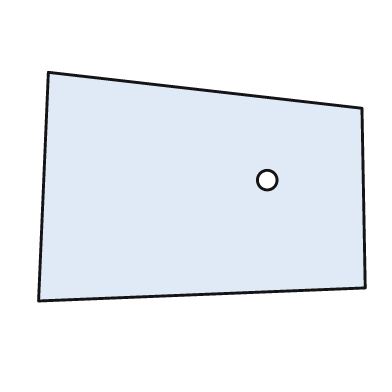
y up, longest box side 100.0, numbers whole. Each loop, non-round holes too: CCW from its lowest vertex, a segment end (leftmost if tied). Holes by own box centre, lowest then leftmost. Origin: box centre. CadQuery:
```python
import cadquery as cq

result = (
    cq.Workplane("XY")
    .moveTo(-50.0, -35.0)
    .lineTo(50.0, -31.0)
    .lineTo(49.0, 24.0)
    .lineTo(-47.0, 35.0)
    .close()
    .moveTo(20.0, 2.0)
    .circle(3.0)
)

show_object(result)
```